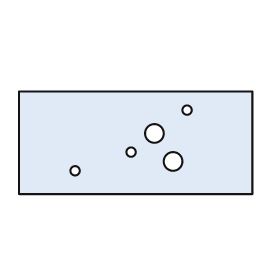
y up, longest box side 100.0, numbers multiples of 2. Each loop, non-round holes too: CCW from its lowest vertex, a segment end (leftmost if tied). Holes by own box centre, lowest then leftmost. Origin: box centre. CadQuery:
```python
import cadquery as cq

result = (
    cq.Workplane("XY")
    .moveTo(-50.0, -22.0)
    .lineTo(50.0, -22.0)
    .lineTo(50.0, 22.0)
    .lineTo(-50.0, 22.0)
    .close()
    .moveTo(-26.0, -12.0)
    .circle(2.0)
    .moveTo(16.0, -8.0)
    .circle(4.0)
    .moveTo(-2.0, -4.0)
    .circle(2.0)
    .moveTo(8.0, 4.0)
    .circle(4.0)
    .moveTo(22.0, 14.0)
    .circle(2.0)
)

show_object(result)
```